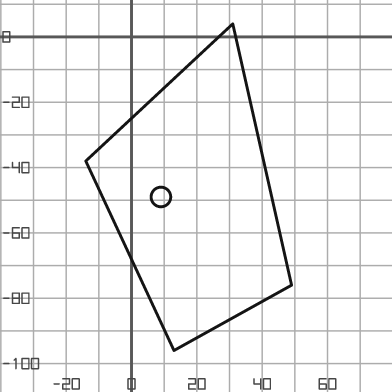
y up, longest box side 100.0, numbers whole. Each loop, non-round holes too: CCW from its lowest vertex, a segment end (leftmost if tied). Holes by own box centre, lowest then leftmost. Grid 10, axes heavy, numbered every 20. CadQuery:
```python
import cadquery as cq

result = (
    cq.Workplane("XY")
    .moveTo(13.0, -96.0)
    .lineTo(49.0, -76.0)
    .lineTo(31.0, 4.0)
    .lineTo(-14.0, -38.0)
    .close()
    .moveTo(9.0, -49.0)
    .circle(3.0)
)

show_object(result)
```